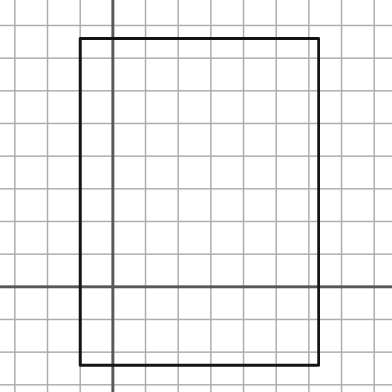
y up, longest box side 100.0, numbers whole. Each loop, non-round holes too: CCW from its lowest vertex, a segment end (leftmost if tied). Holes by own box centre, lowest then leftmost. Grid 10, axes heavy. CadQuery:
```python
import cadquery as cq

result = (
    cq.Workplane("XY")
    .moveTo(-10.0, -24.0)
    .lineTo(63.0, -24.0)
    .lineTo(63.0, 76.0)
    .lineTo(-10.0, 76.0)
    .close()
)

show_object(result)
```